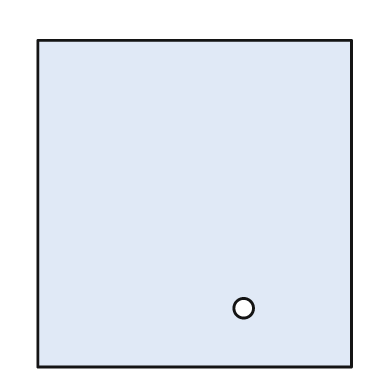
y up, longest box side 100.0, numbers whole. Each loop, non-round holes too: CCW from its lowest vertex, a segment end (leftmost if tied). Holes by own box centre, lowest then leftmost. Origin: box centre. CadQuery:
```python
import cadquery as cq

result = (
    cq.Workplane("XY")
    .moveTo(-48.0, -50.0)
    .lineTo(48.0, -50.0)
    .lineTo(48.0, 50.0)
    .lineTo(-48.0, 50.0)
    .close()
    .moveTo(15.0, -32.0)
    .circle(3.0)
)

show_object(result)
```